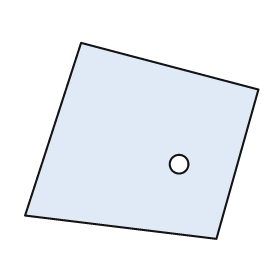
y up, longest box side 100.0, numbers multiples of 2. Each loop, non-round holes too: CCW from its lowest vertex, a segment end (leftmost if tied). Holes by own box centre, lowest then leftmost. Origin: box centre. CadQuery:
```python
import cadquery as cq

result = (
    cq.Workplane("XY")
    .moveTo(32.0, -42.0)
    .lineTo(50.0, 22.0)
    .lineTo(-26.0, 42.0)
    .lineTo(-50.0, -32.0)
    .close()
    .moveTo(16.0, -10.0)
    .circle(4.0)
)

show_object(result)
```